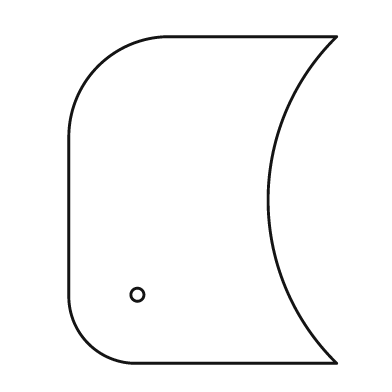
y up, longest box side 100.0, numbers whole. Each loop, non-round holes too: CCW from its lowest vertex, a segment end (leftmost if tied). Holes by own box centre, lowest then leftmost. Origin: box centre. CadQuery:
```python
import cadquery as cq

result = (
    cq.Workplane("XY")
    .moveTo(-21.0, -50.0)
    .lineTo(41.0, -50.0)
    .threePointArc((20.0, 0.0), (41.0, 50.0))
    .lineTo(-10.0, 50.0)
    .threePointArc((-32.0, 41.0), (-41.0, 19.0))
    .lineTo(-41.0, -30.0)
    .threePointArc((-35.0, -44.0), (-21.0, -50.0))
    .close()
    .moveTo(-20.0, -29.0)
    .circle(2.0)
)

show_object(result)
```